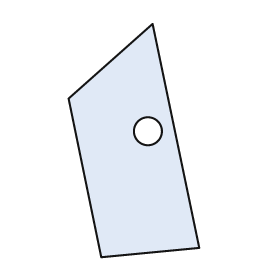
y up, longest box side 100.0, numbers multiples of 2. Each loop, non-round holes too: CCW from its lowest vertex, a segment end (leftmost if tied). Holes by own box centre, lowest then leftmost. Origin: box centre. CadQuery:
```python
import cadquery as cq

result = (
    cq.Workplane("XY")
    .moveTo(-14.0, -50.0)
    .lineTo(28.0, -46.0)
    .lineTo(8.0, 50.0)
    .lineTo(-28.0, 18.0)
    .close()
    .moveTo(6.0, 4.0)
    .circle(6.0)
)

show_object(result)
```